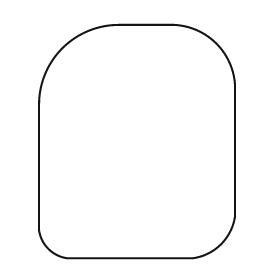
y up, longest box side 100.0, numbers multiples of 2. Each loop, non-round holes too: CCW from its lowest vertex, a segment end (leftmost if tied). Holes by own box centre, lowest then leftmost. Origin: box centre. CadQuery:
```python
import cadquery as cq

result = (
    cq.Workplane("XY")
    .moveTo(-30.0, -50.0)
    .lineTo(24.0, -50.0)
    .threePointArc((36.0, -44.0), (42.0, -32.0))
    .lineTo(42.0, 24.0)
    .threePointArc((34.0, 42.0), (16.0, 50.0))
    .lineTo(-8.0, 50.0)
    .threePointArc((-32.0, 40.0), (-42.0, 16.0))
    .lineTo(-42.0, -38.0)
    .threePointArc((-38.0, -46.0), (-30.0, -50.0))
    .close()
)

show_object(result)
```